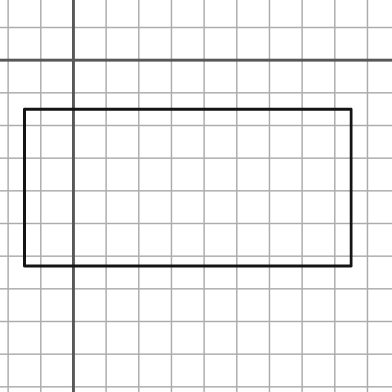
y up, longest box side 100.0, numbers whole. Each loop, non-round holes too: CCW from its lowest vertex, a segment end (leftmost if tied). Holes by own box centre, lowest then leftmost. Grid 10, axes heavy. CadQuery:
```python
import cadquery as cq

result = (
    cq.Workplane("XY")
    .moveTo(-15.0, -63.0)
    .lineTo(85.0, -63.0)
    .lineTo(85.0, -15.0)
    .lineTo(-15.0, -15.0)
    .close()
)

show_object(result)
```